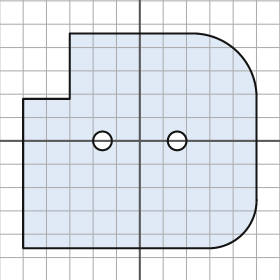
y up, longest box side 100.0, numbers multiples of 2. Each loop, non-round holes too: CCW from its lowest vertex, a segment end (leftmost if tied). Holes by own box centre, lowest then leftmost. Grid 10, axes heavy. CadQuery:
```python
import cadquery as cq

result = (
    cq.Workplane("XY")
    .moveTo(-50.0, -46.0)
    .lineTo(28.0, -46.0)
    .threePointArc((44.0, -40.0), (50.0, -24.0))
    .lineTo(50.0, 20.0)
    .threePointArc((42.0, 38.0), (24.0, 46.0))
    .lineTo(-30.0, 46.0)
    .lineTo(-30.0, 18.0)
    .lineTo(-50.0, 18.0)
    .close()
    .moveTo(-16.0, 0.0)
    .circle(4.0)
    .moveTo(16.0, 0.0)
    .circle(4.0)
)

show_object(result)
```